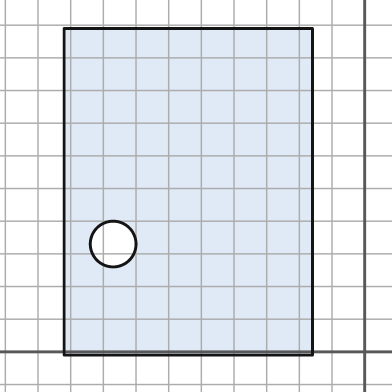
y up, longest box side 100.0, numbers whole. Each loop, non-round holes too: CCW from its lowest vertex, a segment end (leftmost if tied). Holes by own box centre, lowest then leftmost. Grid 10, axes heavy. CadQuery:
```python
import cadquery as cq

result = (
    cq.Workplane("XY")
    .moveTo(-92.0, -1.0)
    .lineTo(-16.0, -1.0)
    .lineTo(-16.0, 99.0)
    .lineTo(-92.0, 99.0)
    .close()
    .moveTo(-77.0, 33.0)
    .circle(7.0)
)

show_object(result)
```